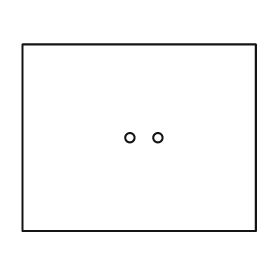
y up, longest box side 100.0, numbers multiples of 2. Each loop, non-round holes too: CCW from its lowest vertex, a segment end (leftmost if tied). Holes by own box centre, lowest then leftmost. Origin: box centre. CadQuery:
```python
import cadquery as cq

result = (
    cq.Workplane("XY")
    .moveTo(-50.0, -40.0)
    .lineTo(50.0, -40.0)
    .lineTo(50.0, 40.0)
    .lineTo(-50.0, 40.0)
    .close()
    .moveTo(-4.0, 0.0)
    .circle(2.0)
    .moveTo(8.0, 0.0)
    .circle(2.0)
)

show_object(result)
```